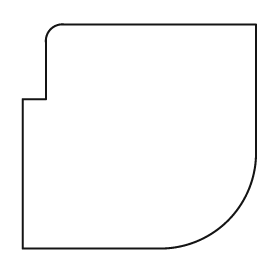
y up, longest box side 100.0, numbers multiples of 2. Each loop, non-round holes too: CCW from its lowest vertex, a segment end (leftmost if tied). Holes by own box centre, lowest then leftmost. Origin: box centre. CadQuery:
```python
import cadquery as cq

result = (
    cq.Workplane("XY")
    .moveTo(-50.0, -48.0)
    .lineTo(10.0, -48.0)
    .threePointArc((38.0, -36.0), (50.0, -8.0))
    .lineTo(50.0, 48.0)
    .lineTo(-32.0, 48.0)
    .threePointArc((-38.0, 46.0), (-40.0, 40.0))
    .lineTo(-40.0, 16.0)
    .lineTo(-50.0, 16.0)
    .close()
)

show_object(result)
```